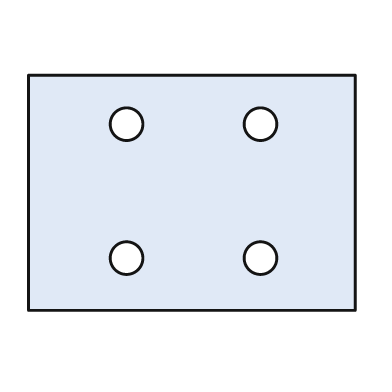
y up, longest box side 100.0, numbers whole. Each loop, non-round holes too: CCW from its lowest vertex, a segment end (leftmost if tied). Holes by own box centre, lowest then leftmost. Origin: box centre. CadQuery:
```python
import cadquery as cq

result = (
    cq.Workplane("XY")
    .moveTo(-50.0, -36.0)
    .lineTo(50.0, -36.0)
    .lineTo(50.0, 36.0)
    .lineTo(-50.0, 36.0)
    .close()
    .moveTo(-20.0, -20.0)
    .circle(5.0)
    .moveTo(21.0, -20.0)
    .circle(5.0)
    .moveTo(-20.0, 21.0)
    .circle(5.0)
    .moveTo(21.0, 21.0)
    .circle(5.0)
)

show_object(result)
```